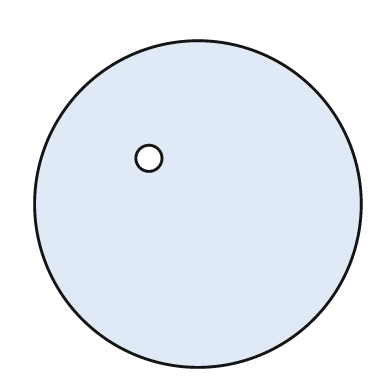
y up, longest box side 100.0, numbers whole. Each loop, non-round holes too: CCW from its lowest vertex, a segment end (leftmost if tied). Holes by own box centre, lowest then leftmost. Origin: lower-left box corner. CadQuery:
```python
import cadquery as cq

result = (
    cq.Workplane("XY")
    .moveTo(50.0, 50.0)
    .circle(50.0)
    .moveTo(35.0, 64.0)
    .circle(4.0)
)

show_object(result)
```